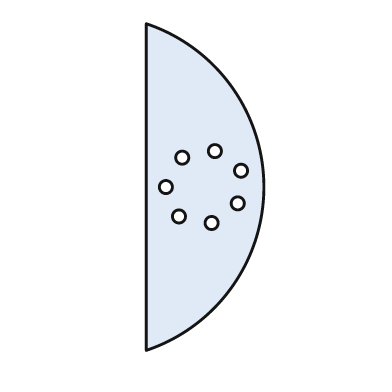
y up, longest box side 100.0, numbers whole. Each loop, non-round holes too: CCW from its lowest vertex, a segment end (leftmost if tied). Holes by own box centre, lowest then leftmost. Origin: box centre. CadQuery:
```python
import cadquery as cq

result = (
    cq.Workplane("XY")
    .moveTo(-18.0, -50.0)
    .threePointArc((18.0, 0.0), (-18.0, 50.0))
    .close()
    .moveTo(2.0, -11.0)
    .circle(2.0)
    .moveTo(-8.0, -9.0)
    .circle(2.0)
    .moveTo(10.0, -5.0)
    .circle(2.0)
    .moveTo(-12.0, 0.0)
    .circle(2.0)
    .moveTo(11.0, 5.0)
    .circle(2.0)
    .moveTo(-7.0, 9.0)
    .circle(2.0)
    .moveTo(3.0, 11.0)
    .circle(2.0)
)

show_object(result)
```